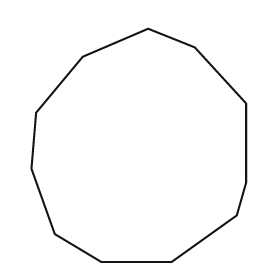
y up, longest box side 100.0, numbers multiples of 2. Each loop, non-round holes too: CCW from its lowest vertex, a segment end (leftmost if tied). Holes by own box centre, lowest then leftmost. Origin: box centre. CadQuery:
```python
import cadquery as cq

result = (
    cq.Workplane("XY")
    .moveTo(-16.0, -50.0)
    .lineTo(14.0, -50.0)
    .lineTo(42.0, -30.0)
    .lineTo(46.0, -16.0)
    .lineTo(46.0, 18.0)
    .lineTo(24.0, 42.0)
    .lineTo(4.0, 50.0)
    .lineTo(-24.0, 38.0)
    .lineTo(-44.0, 14.0)
    .lineTo(-46.0, -10.0)
    .lineTo(-36.0, -38.0)
    .close()
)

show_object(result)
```